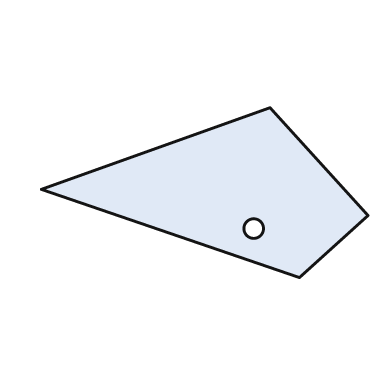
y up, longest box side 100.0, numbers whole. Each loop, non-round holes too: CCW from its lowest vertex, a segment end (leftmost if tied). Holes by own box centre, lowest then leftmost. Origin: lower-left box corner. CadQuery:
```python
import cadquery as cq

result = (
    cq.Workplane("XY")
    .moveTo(79.0, 0.0)
    .lineTo(100.0, 19.0)
    .lineTo(70.0, 52.0)
    .lineTo(0.0, 27.0)
    .close()
    .moveTo(65.0, 15.0)
    .circle(3.0)
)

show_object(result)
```